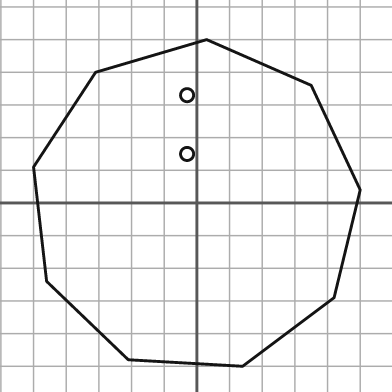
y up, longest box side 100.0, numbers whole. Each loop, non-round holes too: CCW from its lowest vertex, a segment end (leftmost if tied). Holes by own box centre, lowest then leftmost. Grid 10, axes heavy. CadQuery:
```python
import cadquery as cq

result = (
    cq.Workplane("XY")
    .moveTo(14.0, -50.0)
    .lineTo(42.0, -29.0)
    .lineTo(50.0, 4.0)
    .lineTo(35.0, 36.0)
    .lineTo(3.0, 50.0)
    .lineTo(-31.0, 40.0)
    .lineTo(-50.0, 11.0)
    .lineTo(-46.0, -24.0)
    .lineTo(-21.0, -48.0)
    .close()
    .moveTo(-3.0, 15.0)
    .circle(2.0)
    .moveTo(-3.0, 33.0)
    .circle(2.0)
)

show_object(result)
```